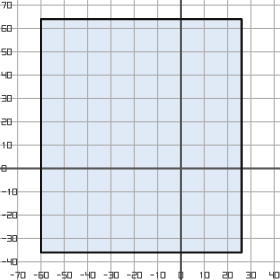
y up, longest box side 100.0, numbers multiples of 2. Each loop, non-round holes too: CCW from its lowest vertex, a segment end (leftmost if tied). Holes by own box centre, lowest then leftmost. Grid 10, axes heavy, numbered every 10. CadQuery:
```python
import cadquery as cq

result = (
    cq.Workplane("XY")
    .moveTo(-60.0, -36.0)
    .lineTo(26.0, -36.0)
    .lineTo(26.0, 64.0)
    .lineTo(-60.0, 64.0)
    .close()
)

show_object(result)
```